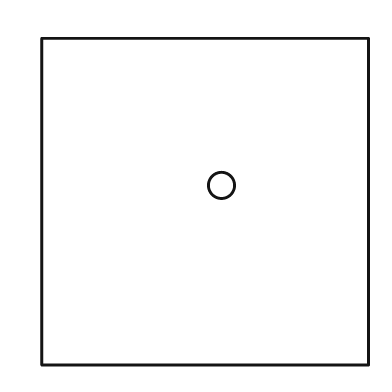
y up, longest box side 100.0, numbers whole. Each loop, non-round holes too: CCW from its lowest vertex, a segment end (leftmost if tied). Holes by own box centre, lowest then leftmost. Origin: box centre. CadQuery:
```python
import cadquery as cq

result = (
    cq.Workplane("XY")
    .moveTo(-50.0, -50.0)
    .lineTo(50.0, -50.0)
    .lineTo(50.0, 50.0)
    .lineTo(-50.0, 50.0)
    .close()
    .moveTo(5.0, 5.0)
    .circle(4.0)
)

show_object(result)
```